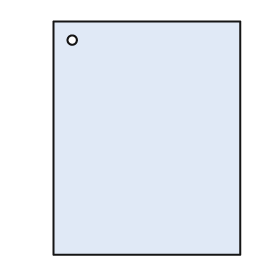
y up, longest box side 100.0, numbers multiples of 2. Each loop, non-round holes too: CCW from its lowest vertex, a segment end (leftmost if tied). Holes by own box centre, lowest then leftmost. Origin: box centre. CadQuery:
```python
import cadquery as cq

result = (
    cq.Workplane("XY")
    .moveTo(-40.0, -50.0)
    .lineTo(40.0, -50.0)
    .lineTo(40.0, 50.0)
    .lineTo(-40.0, 50.0)
    .close()
    .moveTo(-32.0, 42.0)
    .circle(2.0)
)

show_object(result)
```